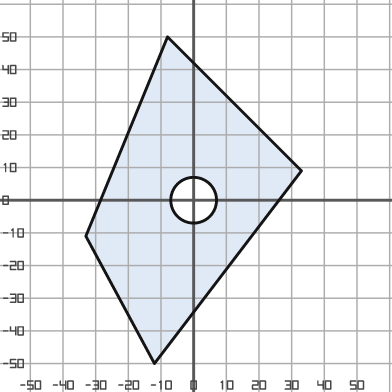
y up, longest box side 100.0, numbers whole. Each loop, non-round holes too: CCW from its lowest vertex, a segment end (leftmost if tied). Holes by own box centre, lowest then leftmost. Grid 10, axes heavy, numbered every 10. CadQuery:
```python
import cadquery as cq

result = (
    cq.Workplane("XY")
    .moveTo(-12.0, -50.0)
    .lineTo(33.0, 9.0)
    .lineTo(-8.0, 50.0)
    .lineTo(-33.0, -11.0)
    .close()
    .moveTo(0.0, 0.0)
    .circle(7.0)
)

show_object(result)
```